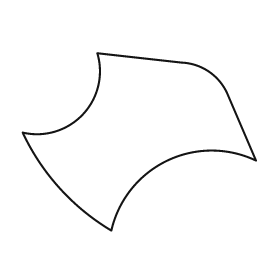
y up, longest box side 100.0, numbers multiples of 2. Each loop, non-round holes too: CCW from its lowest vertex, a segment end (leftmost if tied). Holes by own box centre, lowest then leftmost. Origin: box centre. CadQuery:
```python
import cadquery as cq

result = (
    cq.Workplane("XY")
    .moveTo(-12.0, -38.0)
    .threePointArc((12.0, -8.0), (50.0, -8.0))
    .lineTo(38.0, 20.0)
    .threePointArc((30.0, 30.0), (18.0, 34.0))
    .lineTo(-18.0, 38.0)
    .threePointArc((-24.0, 12.0), (-50.0, 4.0))
    .threePointArc((-34.0, -20.0), (-12.0, -38.0))
    .close()
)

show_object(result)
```